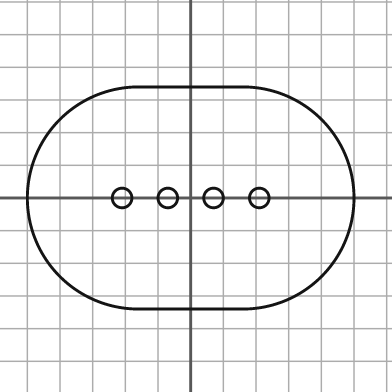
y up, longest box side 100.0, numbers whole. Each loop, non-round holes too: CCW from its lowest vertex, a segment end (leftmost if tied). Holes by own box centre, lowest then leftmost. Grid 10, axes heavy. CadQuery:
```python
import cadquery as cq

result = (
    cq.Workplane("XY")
    .moveTo(-16.0, -34.0)
    .lineTo(16.0, -34.0)
    .threePointArc((50.0, 0.0), (16.0, 34.0))
    .lineTo(-16.0, 34.0)
    .threePointArc((-50.0, 0.0), (-16.0, -34.0))
    .close()
    .moveTo(-21.0, 0.0)
    .circle(3.0)
    .moveTo(-7.0, 0.0)
    .circle(3.0)
    .moveTo(7.0, 0.0)
    .circle(3.0)
    .moveTo(21.0, 0.0)
    .circle(3.0)
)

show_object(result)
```